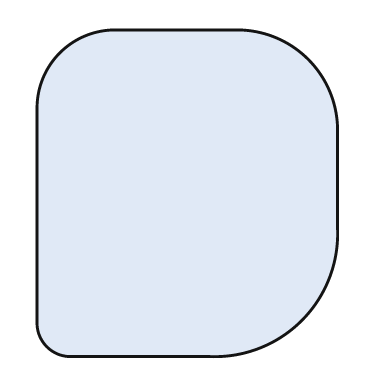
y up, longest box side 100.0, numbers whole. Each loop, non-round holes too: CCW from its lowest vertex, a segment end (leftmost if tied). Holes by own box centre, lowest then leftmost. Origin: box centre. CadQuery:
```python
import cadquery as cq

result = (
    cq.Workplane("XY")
    .moveTo(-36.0, -50.0)
    .lineTo(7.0, -50.0)
    .threePointArc((35.0, -39.0), (46.0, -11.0))
    .lineTo(46.0, 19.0)
    .threePointArc((37.0, 41.0), (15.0, 50.0))
    .lineTo(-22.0, 50.0)
    .threePointArc((-39.0, 43.0), (-46.0, 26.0))
    .lineTo(-46.0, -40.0)
    .threePointArc((-43.0, -47.0), (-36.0, -50.0))
    .close()
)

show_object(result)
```